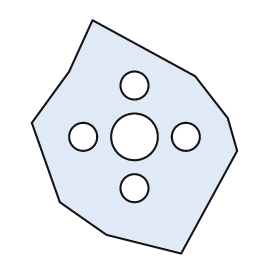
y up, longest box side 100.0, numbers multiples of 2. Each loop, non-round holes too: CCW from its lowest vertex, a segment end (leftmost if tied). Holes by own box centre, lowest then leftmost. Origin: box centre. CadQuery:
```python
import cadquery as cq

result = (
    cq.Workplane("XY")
    .moveTo(20.0, -50.0)
    .lineTo(44.0, -6.0)
    .lineTo(40.0, 8.0)
    .lineTo(26.0, 26.0)
    .lineTo(-18.0, 50.0)
    .lineTo(-28.0, 28.0)
    .lineTo(-44.0, 6.0)
    .lineTo(-32.0, -28.0)
    .lineTo(-12.0, -42.0)
    .close()
    .moveTo(0.0, -22.0)
    .circle(6.0)
    .moveTo(-22.0, 0.0)
    .circle(6.0)
    .moveTo(0.0, 0.0)
    .circle(10.0)
    .moveTo(22.0, 0.0)
    .circle(6.0)
    .moveTo(0.0, 22.0)
    .circle(6.0)
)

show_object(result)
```